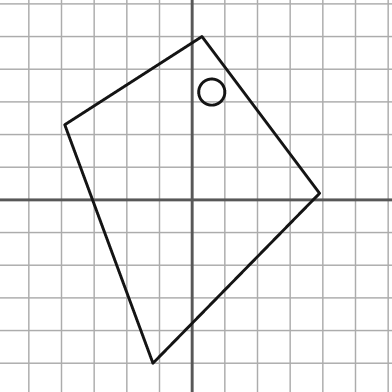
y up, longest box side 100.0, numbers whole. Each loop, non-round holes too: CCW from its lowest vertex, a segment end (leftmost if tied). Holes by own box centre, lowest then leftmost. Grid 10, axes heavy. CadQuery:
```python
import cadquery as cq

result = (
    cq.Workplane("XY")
    .moveTo(-12.0, -50.0)
    .lineTo(39.0, 2.0)
    .lineTo(3.0, 50.0)
    .lineTo(-39.0, 23.0)
    .close()
    .moveTo(6.0, 33.0)
    .circle(4.0)
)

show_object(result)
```